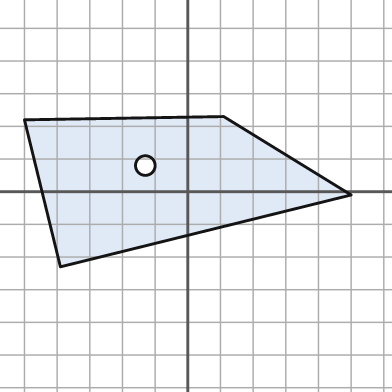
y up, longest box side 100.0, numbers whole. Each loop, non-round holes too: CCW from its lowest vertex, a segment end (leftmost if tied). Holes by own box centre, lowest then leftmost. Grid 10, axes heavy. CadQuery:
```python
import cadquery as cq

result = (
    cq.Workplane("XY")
    .moveTo(-39.0, -23.0)
    .lineTo(50.0, -1.0)
    .lineTo(11.0, 23.0)
    .lineTo(-50.0, 22.0)
    .close()
    .moveTo(-13.0, 8.0)
    .circle(3.0)
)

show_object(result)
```